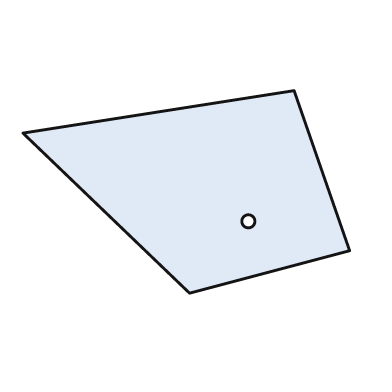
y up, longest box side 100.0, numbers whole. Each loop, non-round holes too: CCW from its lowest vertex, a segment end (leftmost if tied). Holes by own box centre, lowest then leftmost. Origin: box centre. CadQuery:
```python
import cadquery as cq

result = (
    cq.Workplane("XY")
    .moveTo(1.0, -31.0)
    .lineTo(50.0, -18.0)
    .lineTo(33.0, 31.0)
    .lineTo(-50.0, 18.0)
    .close()
    .moveTo(19.0, -9.0)
    .circle(2.0)
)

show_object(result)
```